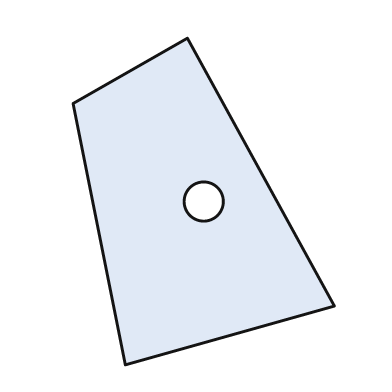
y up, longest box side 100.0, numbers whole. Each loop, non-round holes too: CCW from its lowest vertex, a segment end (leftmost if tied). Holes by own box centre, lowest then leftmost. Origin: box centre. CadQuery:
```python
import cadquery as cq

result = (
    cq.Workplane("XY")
    .moveTo(-24.0, -50.0)
    .lineTo(40.0, -32.0)
    .lineTo(-5.0, 50.0)
    .lineTo(-40.0, 30.0)
    .close()
    .moveTo(0.0, 0.0)
    .circle(6.0)
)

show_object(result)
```